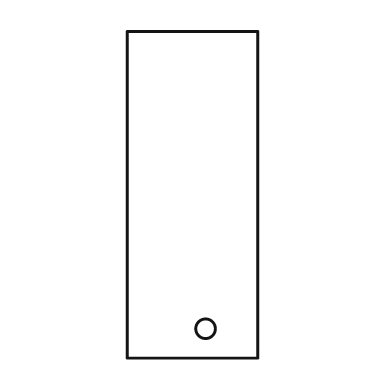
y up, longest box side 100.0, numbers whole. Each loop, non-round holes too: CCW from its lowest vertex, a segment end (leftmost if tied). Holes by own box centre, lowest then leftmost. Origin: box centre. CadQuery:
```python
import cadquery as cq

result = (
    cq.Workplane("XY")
    .moveTo(-20.0, -50.0)
    .lineTo(20.0, -50.0)
    .lineTo(20.0, 50.0)
    .lineTo(-20.0, 50.0)
    .close()
    .moveTo(4.0, -41.0)
    .circle(3.0)
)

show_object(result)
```